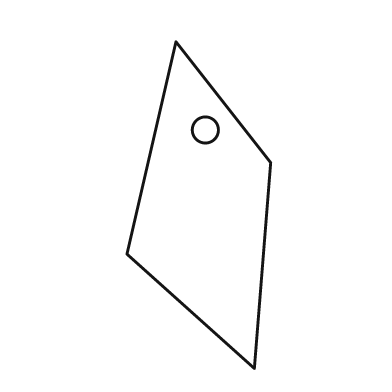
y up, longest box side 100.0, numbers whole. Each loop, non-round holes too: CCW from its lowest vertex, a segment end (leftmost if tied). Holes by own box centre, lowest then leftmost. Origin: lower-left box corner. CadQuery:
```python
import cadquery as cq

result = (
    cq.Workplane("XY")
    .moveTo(39.0, 0.0)
    .lineTo(44.0, 63.0)
    .lineTo(15.0, 100.0)
    .lineTo(0.0, 35.0)
    .close()
    .moveTo(24.0, 73.0)
    .circle(4.0)
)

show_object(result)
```